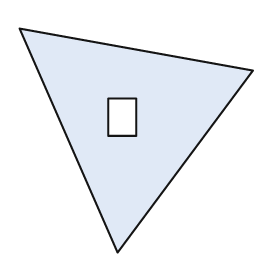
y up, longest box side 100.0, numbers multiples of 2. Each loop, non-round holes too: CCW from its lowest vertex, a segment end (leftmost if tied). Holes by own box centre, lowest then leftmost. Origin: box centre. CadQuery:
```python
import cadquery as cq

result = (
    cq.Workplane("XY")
    .moveTo(-8.0, -48.0)
    .lineTo(50.0, 30.0)
    .lineTo(-50.0, 48.0)
    .close()
    .moveTo(-12.0, 2.0)
    .lineTo(0.0, 2.0)
    .lineTo(0.0, 18.0)
    .lineTo(-12.0, 18.0)
    .close()
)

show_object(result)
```